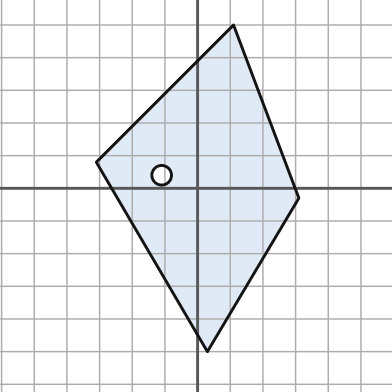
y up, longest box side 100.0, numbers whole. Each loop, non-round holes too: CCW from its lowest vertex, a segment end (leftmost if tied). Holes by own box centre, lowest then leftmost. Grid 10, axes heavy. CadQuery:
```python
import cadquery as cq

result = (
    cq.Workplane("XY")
    .moveTo(3.0, -50.0)
    .lineTo(31.0, -3.0)
    .lineTo(11.0, 50.0)
    .lineTo(-31.0, 8.0)
    .close()
    .moveTo(-11.0, 4.0)
    .circle(3.0)
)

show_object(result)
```